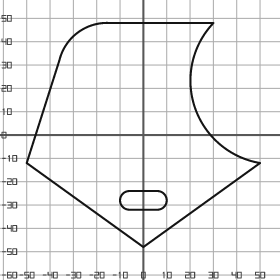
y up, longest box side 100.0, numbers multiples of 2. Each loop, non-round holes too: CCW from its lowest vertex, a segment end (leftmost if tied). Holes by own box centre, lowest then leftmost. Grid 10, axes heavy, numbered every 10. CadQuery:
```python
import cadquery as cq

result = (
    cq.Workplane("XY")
    .moveTo(0.0, -48.0)
    .lineTo(50.0, -12.0)
    .threePointArc((22.0, 12.0), (30.0, 48.0))
    .lineTo(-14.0, 48.0)
    .threePointArc((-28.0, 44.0), (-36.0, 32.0))
    .lineTo(-50.0, -12.0)
    .close()
    .moveTo(-6.0, -32.0)
    .lineTo(6.0, -32.0)
    .threePointArc((10.0, -28.0), (6.0, -24.0))
    .lineTo(-6.0, -24.0)
    .threePointArc((-10.0, -28.0), (-6.0, -32.0))
    .close()
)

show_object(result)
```